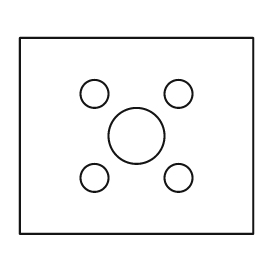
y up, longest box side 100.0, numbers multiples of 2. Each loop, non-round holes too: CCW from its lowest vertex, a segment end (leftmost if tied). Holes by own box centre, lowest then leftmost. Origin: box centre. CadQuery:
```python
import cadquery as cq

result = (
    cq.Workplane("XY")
    .moveTo(-50.0, -42.0)
    .lineTo(50.0, -42.0)
    .lineTo(50.0, 42.0)
    .lineTo(-50.0, 42.0)
    .close()
    .moveTo(-18.0, -18.0)
    .circle(6.0)
    .moveTo(18.0, -18.0)
    .circle(6.0)
    .moveTo(0.0, 0.0)
    .circle(12.0)
    .moveTo(-18.0, 18.0)
    .circle(6.0)
    .moveTo(18.0, 18.0)
    .circle(6.0)
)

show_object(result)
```